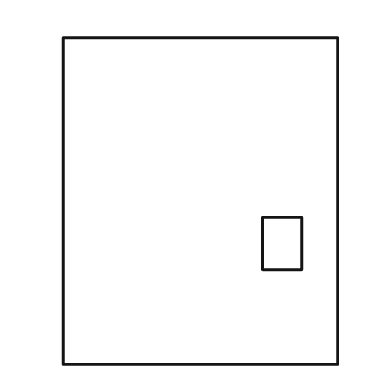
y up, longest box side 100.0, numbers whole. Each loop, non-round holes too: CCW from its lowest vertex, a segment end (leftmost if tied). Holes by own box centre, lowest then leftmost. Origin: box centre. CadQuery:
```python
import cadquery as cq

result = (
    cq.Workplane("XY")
    .moveTo(-42.0, -50.0)
    .lineTo(42.0, -50.0)
    .lineTo(42.0, 50.0)
    .lineTo(-42.0, 50.0)
    .close()
    .moveTo(19.0, -21.0)
    .lineTo(31.0, -21.0)
    .lineTo(31.0, -5.0)
    .lineTo(19.0, -5.0)
    .close()
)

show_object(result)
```